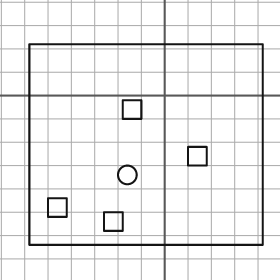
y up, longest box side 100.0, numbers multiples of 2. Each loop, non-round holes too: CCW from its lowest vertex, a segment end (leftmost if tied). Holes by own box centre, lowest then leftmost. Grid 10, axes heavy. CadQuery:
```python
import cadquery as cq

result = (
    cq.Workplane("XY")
    .moveTo(-58.0, -64.0)
    .lineTo(42.0, -64.0)
    .lineTo(42.0, 22.0)
    .lineTo(-58.0, 22.0)
    .close()
    .moveTo(-26.0, -58.0)
    .lineTo(-18.0, -58.0)
    .lineTo(-18.0, -50.0)
    .lineTo(-26.0, -50.0)
    .close()
    .moveTo(-50.0, -52.0)
    .lineTo(-42.0, -52.0)
    .lineTo(-42.0, -44.0)
    .lineTo(-50.0, -44.0)
    .close()
    .moveTo(-16.0, -34.0)
    .circle(4.0)
    .moveTo(10.0, -30.0)
    .lineTo(18.0, -30.0)
    .lineTo(18.0, -22.0)
    .lineTo(10.0, -22.0)
    .close()
    .moveTo(-18.0, -10.0)
    .lineTo(-10.0, -10.0)
    .lineTo(-10.0, -2.0)
    .lineTo(-18.0, -2.0)
    .close()
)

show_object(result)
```